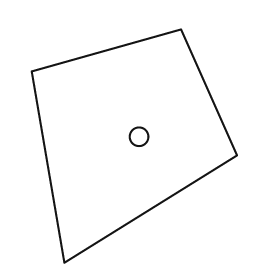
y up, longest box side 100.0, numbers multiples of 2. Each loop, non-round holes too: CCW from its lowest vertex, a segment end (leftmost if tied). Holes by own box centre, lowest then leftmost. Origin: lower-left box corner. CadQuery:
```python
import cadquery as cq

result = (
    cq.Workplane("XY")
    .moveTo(14.0, 0.0)
    .lineTo(88.0, 46.0)
    .lineTo(64.0, 100.0)
    .lineTo(0.0, 82.0)
    .close()
    .moveTo(46.0, 54.0)
    .circle(4.0)
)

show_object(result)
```